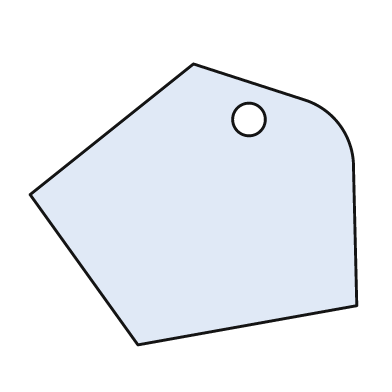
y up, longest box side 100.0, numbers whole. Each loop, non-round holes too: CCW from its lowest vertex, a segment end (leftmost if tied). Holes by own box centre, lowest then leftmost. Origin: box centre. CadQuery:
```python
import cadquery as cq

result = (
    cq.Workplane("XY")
    .moveTo(-17.0, -43.0)
    .lineTo(50.0, -31.0)
    .lineTo(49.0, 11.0)
    .threePointArc((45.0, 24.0), (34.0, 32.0))
    .lineTo(0.0, 43.0)
    .lineTo(-50.0, 3.0)
    .close()
    .moveTo(17.0, 26.0)
    .circle(5.0)
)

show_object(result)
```